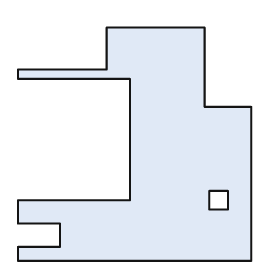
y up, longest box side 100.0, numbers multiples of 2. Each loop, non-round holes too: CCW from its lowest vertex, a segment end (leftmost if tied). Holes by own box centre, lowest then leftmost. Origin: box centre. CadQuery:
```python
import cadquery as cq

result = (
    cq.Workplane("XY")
    .moveTo(-50.0, -50.0)
    .lineTo(50.0, -50.0)
    .lineTo(50.0, 16.0)
    .lineTo(30.0, 16.0)
    .lineTo(30.0, 50.0)
    .lineTo(-12.0, 50.0)
    .lineTo(-12.0, 32.0)
    .lineTo(-50.0, 32.0)
    .lineTo(-50.0, 28.0)
    .lineTo(-2.0, 28.0)
    .lineTo(-2.0, -24.0)
    .lineTo(-50.0, -24.0)
    .lineTo(-50.0, -34.0)
    .lineTo(-32.0, -34.0)
    .lineTo(-32.0, -44.0)
    .lineTo(-50.0, -44.0)
    .close()
    .moveTo(32.0, -28.0)
    .lineTo(40.0, -28.0)
    .lineTo(40.0, -20.0)
    .lineTo(32.0, -20.0)
    .close()
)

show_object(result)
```